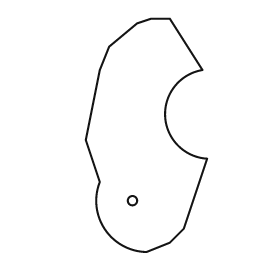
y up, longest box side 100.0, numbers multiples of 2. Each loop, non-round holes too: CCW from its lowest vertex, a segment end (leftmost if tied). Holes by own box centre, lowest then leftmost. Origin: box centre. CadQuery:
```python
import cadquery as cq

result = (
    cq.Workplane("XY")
    .moveTo(0.0, -50.0)
    .lineTo(10.0, -46.0)
    .lineTo(16.0, -40.0)
    .lineTo(26.0, -10.0)
    .threePointArc((8.0, 8.0), (24.0, 28.0))
    .lineTo(10.0, 50.0)
    .lineTo(2.0, 50.0)
    .lineTo(-4.0, 48.0)
    .lineTo(-16.0, 38.0)
    .lineTo(-20.0, 28.0)
    .lineTo(-26.0, -2.0)
    .lineTo(-20.0, -20.0)
    .threePointArc((-18.0, -40.0), (0.0, -50.0))
    .close()
    .moveTo(-6.0, -28.0)
    .circle(2.0)
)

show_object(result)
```